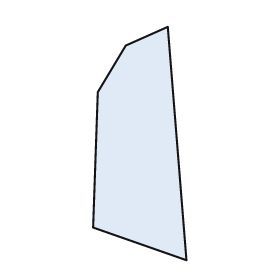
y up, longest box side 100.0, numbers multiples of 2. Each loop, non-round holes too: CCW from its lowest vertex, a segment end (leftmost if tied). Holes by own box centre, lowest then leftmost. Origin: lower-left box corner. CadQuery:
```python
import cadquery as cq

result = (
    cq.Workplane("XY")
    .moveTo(40.0, 0.0)
    .lineTo(32.0, 100.0)
    .lineTo(14.0, 92.0)
    .lineTo(2.0, 72.0)
    .lineTo(0.0, 14.0)
    .close()
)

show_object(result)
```